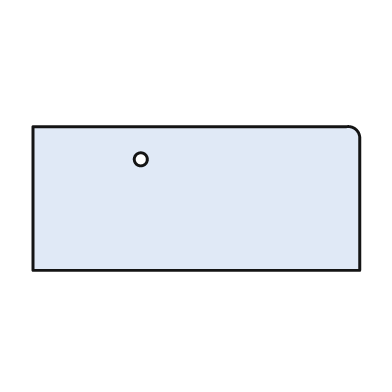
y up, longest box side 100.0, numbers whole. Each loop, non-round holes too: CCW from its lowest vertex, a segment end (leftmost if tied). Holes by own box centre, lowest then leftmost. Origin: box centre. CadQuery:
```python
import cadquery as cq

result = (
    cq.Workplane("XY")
    .moveTo(-50.0, -22.0)
    .lineTo(50.0, -22.0)
    .lineTo(50.0, 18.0)
    .threePointArc((49.0, 21.0), (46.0, 22.0))
    .lineTo(-50.0, 22.0)
    .close()
    .moveTo(-17.0, 12.0)
    .circle(2.0)
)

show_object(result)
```